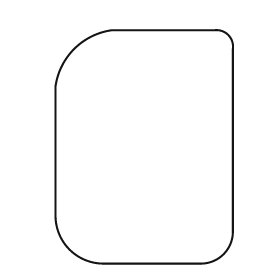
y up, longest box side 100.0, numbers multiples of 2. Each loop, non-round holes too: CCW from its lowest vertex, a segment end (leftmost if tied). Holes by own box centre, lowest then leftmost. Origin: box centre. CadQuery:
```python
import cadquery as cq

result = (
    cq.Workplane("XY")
    .moveTo(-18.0, -50.0)
    .lineTo(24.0, -50.0)
    .threePointArc((34.0, -46.0), (38.0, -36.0))
    .lineTo(38.0, 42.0)
    .threePointArc((36.0, 48.0), (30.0, 50.0))
    .lineTo(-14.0, 50.0)
    .threePointArc((-30.0, 42.0), (-38.0, 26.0))
    .lineTo(-38.0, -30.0)
    .threePointArc((-32.0, -44.0), (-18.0, -50.0))
    .close()
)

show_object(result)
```